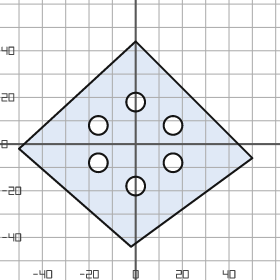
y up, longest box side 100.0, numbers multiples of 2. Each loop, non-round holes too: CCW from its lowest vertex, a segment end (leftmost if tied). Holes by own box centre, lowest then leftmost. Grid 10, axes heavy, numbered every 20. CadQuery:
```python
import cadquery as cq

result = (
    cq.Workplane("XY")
    .moveTo(-2.0, -44.0)
    .lineTo(50.0, -6.0)
    .lineTo(0.0, 44.0)
    .lineTo(-50.0, -2.0)
    .close()
    .moveTo(0.0, -18.0)
    .circle(4.0)
    .moveTo(-16.0, -8.0)
    .circle(4.0)
    .moveTo(16.0, -8.0)
    .circle(4.0)
    .moveTo(-16.0, 8.0)
    .circle(4.0)
    .moveTo(16.0, 8.0)
    .circle(4.0)
    .moveTo(0.0, 18.0)
    .circle(4.0)
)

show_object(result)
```